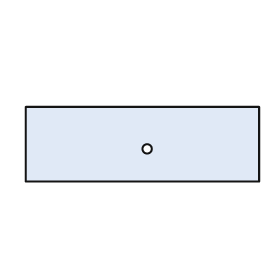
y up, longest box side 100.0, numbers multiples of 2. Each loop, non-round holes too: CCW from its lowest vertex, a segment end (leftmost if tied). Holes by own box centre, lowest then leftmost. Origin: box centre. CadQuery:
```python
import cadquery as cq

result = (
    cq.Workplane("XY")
    .moveTo(-50.0, -16.0)
    .lineTo(50.0, -16.0)
    .lineTo(50.0, 16.0)
    .lineTo(-50.0, 16.0)
    .close()
    .moveTo(2.0, -2.0)
    .circle(2.0)
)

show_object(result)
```